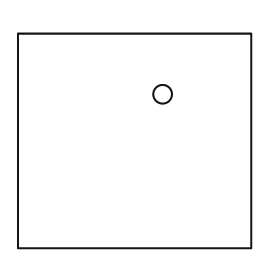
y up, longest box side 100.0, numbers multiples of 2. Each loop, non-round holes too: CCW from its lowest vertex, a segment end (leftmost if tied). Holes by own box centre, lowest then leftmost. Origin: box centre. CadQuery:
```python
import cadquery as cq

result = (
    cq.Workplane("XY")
    .moveTo(-50.0, -46.0)
    .lineTo(50.0, -46.0)
    .lineTo(50.0, 46.0)
    .lineTo(-50.0, 46.0)
    .close()
    .moveTo(12.0, 20.0)
    .circle(4.0)
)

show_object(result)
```